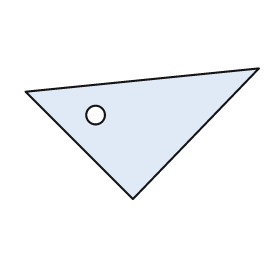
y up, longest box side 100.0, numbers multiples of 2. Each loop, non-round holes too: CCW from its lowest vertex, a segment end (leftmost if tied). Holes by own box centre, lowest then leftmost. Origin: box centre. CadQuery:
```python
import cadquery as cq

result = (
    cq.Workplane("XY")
    .moveTo(-4.0, -28.0)
    .lineTo(50.0, 28.0)
    .lineTo(-50.0, 18.0)
    .close()
    .moveTo(-20.0, 8.0)
    .circle(4.0)
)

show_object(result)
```